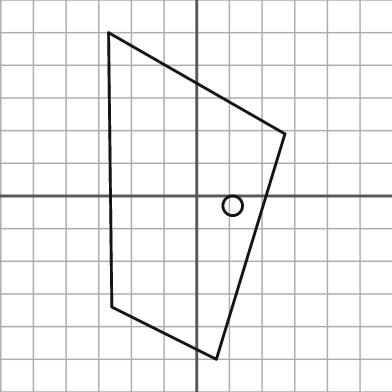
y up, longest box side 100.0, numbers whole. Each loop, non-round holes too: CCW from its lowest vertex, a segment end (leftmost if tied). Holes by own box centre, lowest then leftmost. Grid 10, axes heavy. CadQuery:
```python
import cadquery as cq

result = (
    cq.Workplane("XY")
    .moveTo(6.0, -50.0)
    .lineTo(27.0, 19.0)
    .lineTo(-27.0, 50.0)
    .lineTo(-26.0, -34.0)
    .close()
    .moveTo(11.0, -3.0)
    .circle(3.0)
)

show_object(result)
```